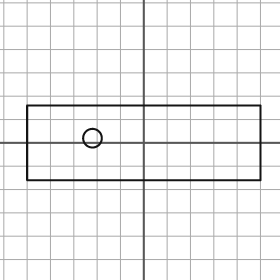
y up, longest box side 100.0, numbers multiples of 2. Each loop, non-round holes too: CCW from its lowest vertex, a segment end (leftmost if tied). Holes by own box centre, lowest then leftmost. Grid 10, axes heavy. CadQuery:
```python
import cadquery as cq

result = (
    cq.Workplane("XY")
    .moveTo(-50.0, -16.0)
    .lineTo(50.0, -16.0)
    .lineTo(50.0, 16.0)
    .lineTo(-50.0, 16.0)
    .close()
    .moveTo(-22.0, 2.0)
    .circle(4.0)
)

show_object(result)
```